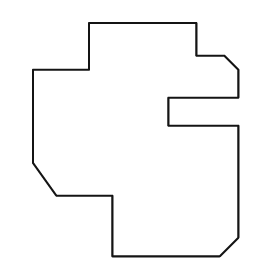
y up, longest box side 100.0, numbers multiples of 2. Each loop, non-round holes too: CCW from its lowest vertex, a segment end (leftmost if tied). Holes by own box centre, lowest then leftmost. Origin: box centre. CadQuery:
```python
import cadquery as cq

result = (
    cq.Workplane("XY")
    .moveTo(-10.0, -50.0)
    .lineTo(36.0, -50.0)
    .lineTo(44.0, -42.0)
    .lineTo(44.0, 6.0)
    .lineTo(14.0, 6.0)
    .lineTo(14.0, 18.0)
    .lineTo(44.0, 18.0)
    .lineTo(44.0, 30.0)
    .lineTo(38.0, 36.0)
    .lineTo(26.0, 36.0)
    .lineTo(26.0, 50.0)
    .lineTo(-20.0, 50.0)
    .lineTo(-20.0, 30.0)
    .lineTo(-44.0, 30.0)
    .lineTo(-44.0, -10.0)
    .lineTo(-34.0, -24.0)
    .lineTo(-10.0, -24.0)
    .close()
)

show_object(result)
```